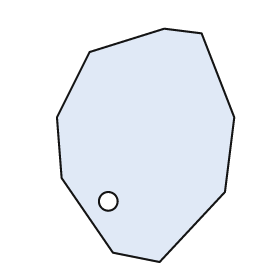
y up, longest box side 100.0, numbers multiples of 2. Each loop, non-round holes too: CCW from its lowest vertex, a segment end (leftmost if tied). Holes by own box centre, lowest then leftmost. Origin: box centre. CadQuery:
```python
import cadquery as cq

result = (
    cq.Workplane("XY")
    .moveTo(6.0, -50.0)
    .lineTo(34.0, -20.0)
    .lineTo(38.0, 12.0)
    .lineTo(24.0, 48.0)
    .lineTo(8.0, 50.0)
    .lineTo(-24.0, 40.0)
    .lineTo(-38.0, 12.0)
    .lineTo(-36.0, -14.0)
    .lineTo(-14.0, -46.0)
    .close()
    .moveTo(-16.0, -24.0)
    .circle(4.0)
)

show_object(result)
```